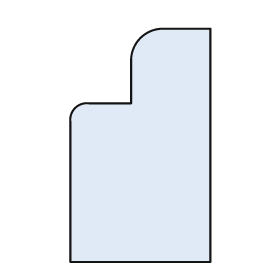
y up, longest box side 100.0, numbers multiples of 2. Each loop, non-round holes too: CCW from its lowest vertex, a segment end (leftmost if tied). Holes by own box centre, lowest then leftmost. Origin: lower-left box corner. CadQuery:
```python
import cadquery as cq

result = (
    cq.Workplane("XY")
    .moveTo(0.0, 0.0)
    .lineTo(60.0, 0.0)
    .lineTo(60.0, 100.0)
    .lineTo(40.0, 100.0)
    .threePointArc((30.0, 96.0), (26.0, 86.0))
    .lineTo(26.0, 68.0)
    .lineTo(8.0, 68.0)
    .threePointArc((2.0, 66.0), (0.0, 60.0))
    .close()
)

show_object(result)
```